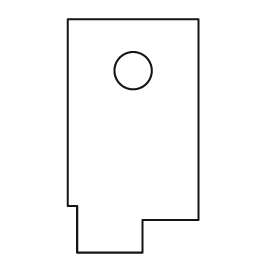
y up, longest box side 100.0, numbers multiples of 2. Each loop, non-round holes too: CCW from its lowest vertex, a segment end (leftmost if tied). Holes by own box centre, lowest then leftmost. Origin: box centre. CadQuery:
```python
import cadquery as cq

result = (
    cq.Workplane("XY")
    .moveTo(-24.0, -50.0)
    .lineTo(4.0, -50.0)
    .lineTo(4.0, -36.0)
    .lineTo(28.0, -36.0)
    .lineTo(28.0, 50.0)
    .lineTo(-28.0, 50.0)
    .lineTo(-28.0, -30.0)
    .lineTo(-24.0, -30.0)
    .close()
    .moveTo(0.0, 28.0)
    .circle(8.0)
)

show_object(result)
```